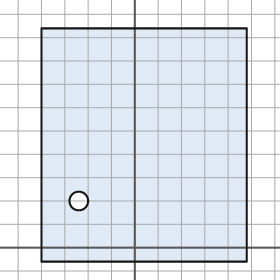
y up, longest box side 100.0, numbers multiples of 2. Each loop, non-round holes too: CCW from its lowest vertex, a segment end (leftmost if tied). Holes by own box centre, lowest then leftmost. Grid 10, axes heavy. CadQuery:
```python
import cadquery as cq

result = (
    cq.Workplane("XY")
    .moveTo(-40.0, -6.0)
    .lineTo(48.0, -6.0)
    .lineTo(48.0, 94.0)
    .lineTo(-40.0, 94.0)
    .close()
    .moveTo(-24.0, 20.0)
    .circle(4.0)
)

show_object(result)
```